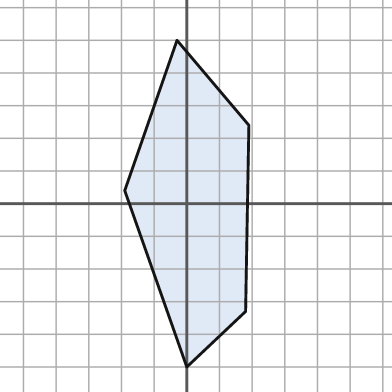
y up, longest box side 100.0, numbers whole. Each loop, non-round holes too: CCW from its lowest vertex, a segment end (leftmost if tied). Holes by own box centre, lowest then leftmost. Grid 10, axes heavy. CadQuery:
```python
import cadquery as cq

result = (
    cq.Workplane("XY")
    .moveTo(0.0, -50.0)
    .lineTo(18.0, -33.0)
    .lineTo(19.0, 24.0)
    .lineTo(-3.0, 50.0)
    .lineTo(-19.0, 4.0)
    .close()
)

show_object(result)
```